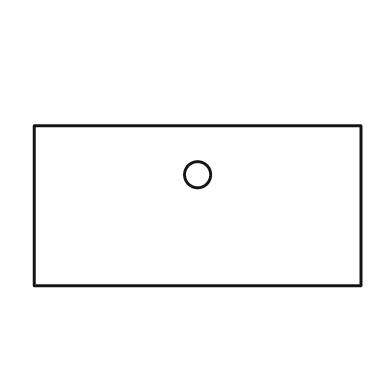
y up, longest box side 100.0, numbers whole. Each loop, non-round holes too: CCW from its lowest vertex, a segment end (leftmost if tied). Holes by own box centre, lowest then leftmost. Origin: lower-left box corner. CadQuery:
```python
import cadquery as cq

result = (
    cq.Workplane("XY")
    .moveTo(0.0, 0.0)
    .lineTo(100.0, 0.0)
    .lineTo(100.0, 49.0)
    .lineTo(0.0, 49.0)
    .close()
    .moveTo(50.0, 34.0)
    .circle(4.0)
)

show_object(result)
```